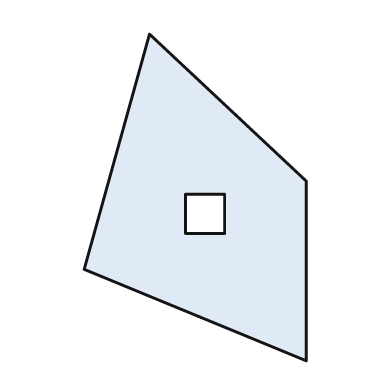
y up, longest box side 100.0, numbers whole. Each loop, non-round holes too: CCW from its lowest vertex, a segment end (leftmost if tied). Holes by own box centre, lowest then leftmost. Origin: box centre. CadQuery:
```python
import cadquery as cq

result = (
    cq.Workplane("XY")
    .moveTo(34.0, -50.0)
    .lineTo(34.0, 5.0)
    .lineTo(-14.0, 50.0)
    .lineTo(-34.0, -22.0)
    .close()
    .moveTo(-3.0, -11.0)
    .lineTo(9.0, -11.0)
    .lineTo(9.0, 1.0)
    .lineTo(-3.0, 1.0)
    .close()
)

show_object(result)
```